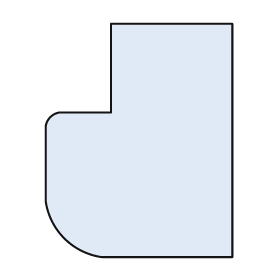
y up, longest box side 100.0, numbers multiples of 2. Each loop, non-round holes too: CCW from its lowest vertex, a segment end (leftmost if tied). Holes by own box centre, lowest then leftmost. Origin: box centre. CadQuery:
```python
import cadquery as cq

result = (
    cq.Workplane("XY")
    .moveTo(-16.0, -50.0)
    .lineTo(40.0, -50.0)
    .lineTo(40.0, 50.0)
    .lineTo(-12.0, 50.0)
    .lineTo(-12.0, 12.0)
    .lineTo(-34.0, 12.0)
    .threePointArc((-38.0, 10.0), (-40.0, 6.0))
    .lineTo(-40.0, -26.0)
    .threePointArc((-32.0, -42.0), (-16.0, -50.0))
    .close()
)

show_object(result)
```